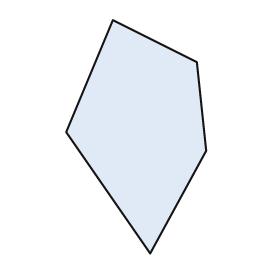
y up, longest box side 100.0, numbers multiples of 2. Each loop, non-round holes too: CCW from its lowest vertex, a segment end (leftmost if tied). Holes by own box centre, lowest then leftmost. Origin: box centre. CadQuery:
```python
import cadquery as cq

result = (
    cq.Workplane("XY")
    .moveTo(6.0, -50.0)
    .lineTo(30.0, -6.0)
    .lineTo(26.0, 32.0)
    .lineTo(-10.0, 50.0)
    .lineTo(-30.0, 2.0)
    .close()
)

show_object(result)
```